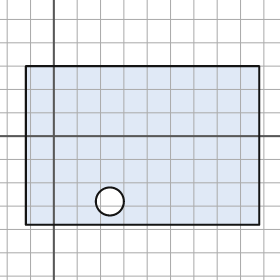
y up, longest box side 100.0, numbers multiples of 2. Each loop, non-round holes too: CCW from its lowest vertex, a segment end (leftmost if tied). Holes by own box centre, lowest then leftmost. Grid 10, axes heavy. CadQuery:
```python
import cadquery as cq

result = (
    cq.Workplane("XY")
    .moveTo(-12.0, -38.0)
    .lineTo(88.0, -38.0)
    .lineTo(88.0, 30.0)
    .lineTo(-12.0, 30.0)
    .close()
    .moveTo(24.0, -28.0)
    .circle(6.0)
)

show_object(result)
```